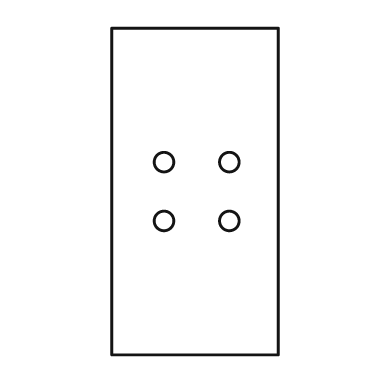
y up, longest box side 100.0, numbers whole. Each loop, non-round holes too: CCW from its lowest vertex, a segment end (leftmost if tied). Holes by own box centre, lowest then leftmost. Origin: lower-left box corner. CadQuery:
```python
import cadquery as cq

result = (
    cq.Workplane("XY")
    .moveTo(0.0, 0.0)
    .lineTo(51.0, 0.0)
    .lineTo(51.0, 100.0)
    .lineTo(0.0, 100.0)
    .close()
    .moveTo(16.0, 41.0)
    .circle(3.0)
    .moveTo(36.0, 41.0)
    .circle(3.0)
    .moveTo(16.0, 59.0)
    .circle(3.0)
    .moveTo(36.0, 59.0)
    .circle(3.0)
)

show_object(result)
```